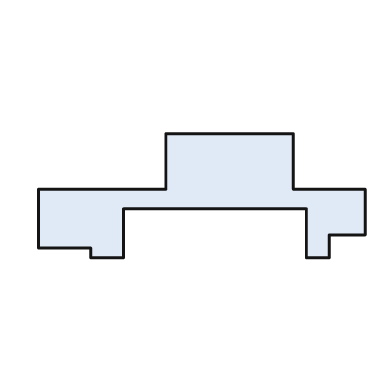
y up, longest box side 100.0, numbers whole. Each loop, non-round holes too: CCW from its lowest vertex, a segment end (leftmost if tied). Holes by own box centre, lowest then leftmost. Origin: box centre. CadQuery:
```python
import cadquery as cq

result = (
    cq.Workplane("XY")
    .moveTo(-34.0, -19.0)
    .lineTo(-24.0, -19.0)
    .lineTo(-24.0, -4.0)
    .lineTo(32.0, -4.0)
    .lineTo(32.0, -19.0)
    .lineTo(39.0, -19.0)
    .lineTo(39.0, -12.0)
    .lineTo(50.0, -12.0)
    .lineTo(50.0, 2.0)
    .lineTo(28.0, 2.0)
    .lineTo(28.0, 19.0)
    .lineTo(-11.0, 19.0)
    .lineTo(-11.0, 2.0)
    .lineTo(-50.0, 2.0)
    .lineTo(-50.0, -16.0)
    .lineTo(-34.0, -16.0)
    .close()
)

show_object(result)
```